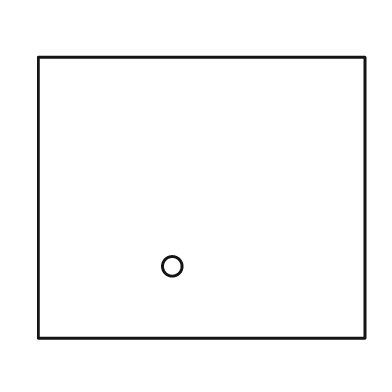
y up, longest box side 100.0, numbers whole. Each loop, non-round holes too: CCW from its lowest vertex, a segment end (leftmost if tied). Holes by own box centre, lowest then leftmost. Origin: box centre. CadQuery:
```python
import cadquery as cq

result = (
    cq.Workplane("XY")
    .moveTo(-50.0, -43.0)
    .lineTo(50.0, -43.0)
    .lineTo(50.0, 43.0)
    .lineTo(-50.0, 43.0)
    .close()
    .moveTo(-9.0, -21.0)
    .circle(3.0)
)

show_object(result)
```